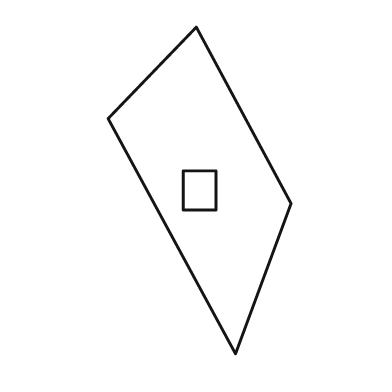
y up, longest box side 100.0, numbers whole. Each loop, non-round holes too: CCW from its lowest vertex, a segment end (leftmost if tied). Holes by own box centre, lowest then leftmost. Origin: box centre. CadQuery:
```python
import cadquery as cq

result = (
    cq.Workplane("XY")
    .moveTo(11.0, -50.0)
    .lineTo(28.0, -4.0)
    .lineTo(-1.0, 50.0)
    .lineTo(-28.0, 22.0)
    .close()
    .moveTo(-5.0, -6.0)
    .lineTo(5.0, -6.0)
    .lineTo(5.0, 6.0)
    .lineTo(-5.0, 6.0)
    .close()
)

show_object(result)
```